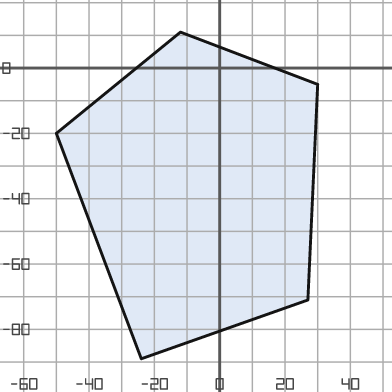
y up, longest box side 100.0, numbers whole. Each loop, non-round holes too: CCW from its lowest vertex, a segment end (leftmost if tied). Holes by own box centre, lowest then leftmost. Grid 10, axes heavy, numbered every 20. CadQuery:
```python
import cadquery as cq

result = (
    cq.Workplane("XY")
    .moveTo(-24.0, -89.0)
    .lineTo(27.0, -71.0)
    .lineTo(30.0, -5.0)
    .lineTo(-12.0, 11.0)
    .lineTo(-50.0, -20.0)
    .close()
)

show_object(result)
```